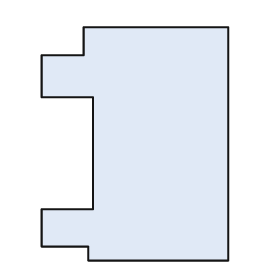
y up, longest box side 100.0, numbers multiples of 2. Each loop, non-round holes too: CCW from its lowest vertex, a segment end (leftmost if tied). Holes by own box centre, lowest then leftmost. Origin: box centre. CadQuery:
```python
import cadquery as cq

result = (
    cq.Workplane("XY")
    .moveTo(-20.0, -50.0)
    .lineTo(40.0, -50.0)
    .lineTo(40.0, 50.0)
    .lineTo(-22.0, 50.0)
    .lineTo(-22.0, 38.0)
    .lineTo(-40.0, 38.0)
    .lineTo(-40.0, 20.0)
    .lineTo(-18.0, 20.0)
    .lineTo(-18.0, -28.0)
    .lineTo(-40.0, -28.0)
    .lineTo(-40.0, -44.0)
    .lineTo(-20.0, -44.0)
    .close()
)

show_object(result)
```